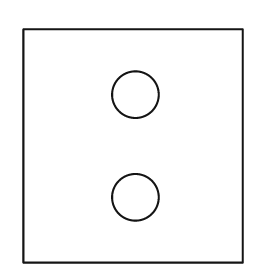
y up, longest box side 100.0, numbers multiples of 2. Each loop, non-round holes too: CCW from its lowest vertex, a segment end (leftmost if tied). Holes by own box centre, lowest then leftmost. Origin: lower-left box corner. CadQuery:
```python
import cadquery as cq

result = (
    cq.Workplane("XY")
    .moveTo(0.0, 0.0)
    .lineTo(94.0, 0.0)
    .lineTo(94.0, 100.0)
    .lineTo(0.0, 100.0)
    .close()
    .moveTo(48.0, 28.0)
    .circle(10.0)
    .moveTo(48.0, 72.0)
    .circle(10.0)
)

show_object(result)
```